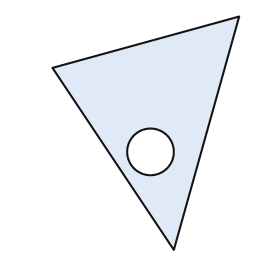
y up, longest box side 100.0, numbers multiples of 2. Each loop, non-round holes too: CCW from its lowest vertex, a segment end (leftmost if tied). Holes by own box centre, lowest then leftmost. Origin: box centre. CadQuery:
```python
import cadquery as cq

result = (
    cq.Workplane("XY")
    .moveTo(12.0, -50.0)
    .lineTo(40.0, 50.0)
    .lineTo(-40.0, 28.0)
    .close()
    .moveTo(2.0, -8.0)
    .circle(10.0)
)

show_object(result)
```